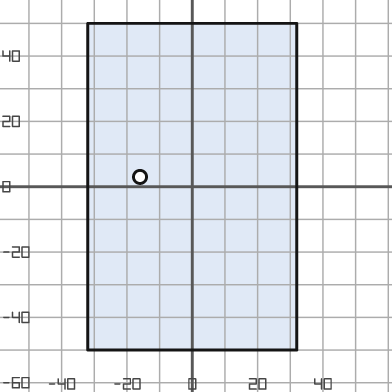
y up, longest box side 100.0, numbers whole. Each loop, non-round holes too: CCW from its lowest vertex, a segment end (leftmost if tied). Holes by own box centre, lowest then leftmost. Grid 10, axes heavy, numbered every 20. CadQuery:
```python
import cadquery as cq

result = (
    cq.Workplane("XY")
    .moveTo(-32.0, -50.0)
    .lineTo(32.0, -50.0)
    .lineTo(32.0, 50.0)
    .lineTo(-32.0, 50.0)
    .close()
    .moveTo(-16.0, 3.0)
    .circle(2.0)
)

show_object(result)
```